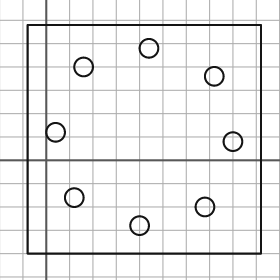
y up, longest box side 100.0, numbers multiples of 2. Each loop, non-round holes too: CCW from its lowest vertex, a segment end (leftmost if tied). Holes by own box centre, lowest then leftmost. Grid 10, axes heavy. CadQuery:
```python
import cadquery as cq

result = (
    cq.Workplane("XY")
    .moveTo(-8.0, -40.0)
    .lineTo(92.0, -40.0)
    .lineTo(92.0, 58.0)
    .lineTo(-8.0, 58.0)
    .close()
    .moveTo(40.0, -28.0)
    .circle(4.0)
    .moveTo(68.0, -20.0)
    .circle(4.0)
    .moveTo(12.0, -16.0)
    .circle(4.0)
    .moveTo(80.0, 8.0)
    .circle(4.0)
    .moveTo(4.0, 12.0)
    .circle(4.0)
    .moveTo(72.0, 36.0)
    .circle(4.0)
    .moveTo(16.0, 40.0)
    .circle(4.0)
    .moveTo(44.0, 48.0)
    .circle(4.0)
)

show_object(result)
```